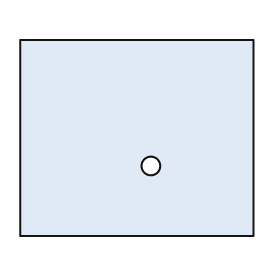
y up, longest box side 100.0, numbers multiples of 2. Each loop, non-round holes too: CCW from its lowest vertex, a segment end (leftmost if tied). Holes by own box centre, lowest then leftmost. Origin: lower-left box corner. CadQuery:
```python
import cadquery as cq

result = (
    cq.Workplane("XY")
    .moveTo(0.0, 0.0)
    .lineTo(100.0, 0.0)
    .lineTo(100.0, 84.0)
    .lineTo(0.0, 84.0)
    .close()
    .moveTo(56.0, 30.0)
    .circle(4.0)
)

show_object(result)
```